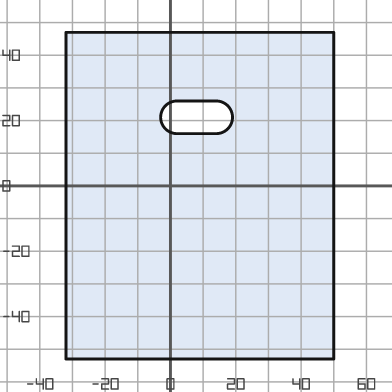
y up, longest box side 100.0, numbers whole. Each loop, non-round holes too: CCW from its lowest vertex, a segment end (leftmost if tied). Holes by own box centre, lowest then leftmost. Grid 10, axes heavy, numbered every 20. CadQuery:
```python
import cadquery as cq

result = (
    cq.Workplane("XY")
    .moveTo(-32.0, -53.0)
    .lineTo(50.0, -53.0)
    .lineTo(50.0, 47.0)
    .lineTo(-32.0, 47.0)
    .close()
    .moveTo(2.0, 16.0)
    .lineTo(14.0, 16.0)
    .threePointArc((19.0, 21.0), (14.0, 26.0))
    .lineTo(2.0, 26.0)
    .threePointArc((-3.0, 21.0), (2.0, 16.0))
    .close()
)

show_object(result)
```